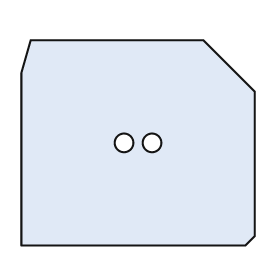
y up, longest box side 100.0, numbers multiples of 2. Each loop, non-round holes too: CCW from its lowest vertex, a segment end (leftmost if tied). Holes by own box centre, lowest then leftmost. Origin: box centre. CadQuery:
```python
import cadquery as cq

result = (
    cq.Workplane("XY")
    .moveTo(-50.0, -44.0)
    .lineTo(46.0, -44.0)
    .lineTo(50.0, -40.0)
    .lineTo(50.0, 22.0)
    .lineTo(28.0, 44.0)
    .lineTo(-46.0, 44.0)
    .lineTo(-50.0, 30.0)
    .close()
    .moveTo(-6.0, 0.0)
    .circle(4.0)
    .moveTo(6.0, 0.0)
    .circle(4.0)
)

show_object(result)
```